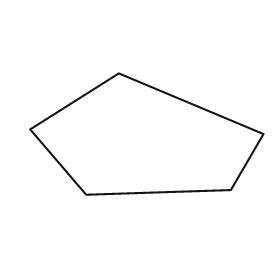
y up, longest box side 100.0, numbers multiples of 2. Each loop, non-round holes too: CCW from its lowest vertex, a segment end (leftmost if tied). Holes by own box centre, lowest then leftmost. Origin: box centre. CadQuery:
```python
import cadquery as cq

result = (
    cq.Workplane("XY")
    .moveTo(-26.0, -26.0)
    .lineTo(36.0, -24.0)
    .lineTo(50.0, 0.0)
    .lineTo(-12.0, 26.0)
    .lineTo(-50.0, 2.0)
    .close()
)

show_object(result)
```